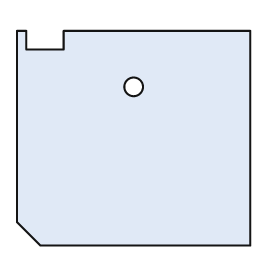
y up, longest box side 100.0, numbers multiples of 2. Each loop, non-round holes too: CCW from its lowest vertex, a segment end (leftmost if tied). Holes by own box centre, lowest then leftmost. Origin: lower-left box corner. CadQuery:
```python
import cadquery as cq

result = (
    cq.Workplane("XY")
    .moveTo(10.0, 0.0)
    .lineTo(100.0, 0.0)
    .lineTo(100.0, 92.0)
    .lineTo(20.0, 92.0)
    .lineTo(20.0, 84.0)
    .lineTo(4.0, 84.0)
    .lineTo(4.0, 92.0)
    .lineTo(0.0, 92.0)
    .lineTo(0.0, 10.0)
    .close()
    .moveTo(50.0, 68.0)
    .circle(4.0)
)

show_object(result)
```